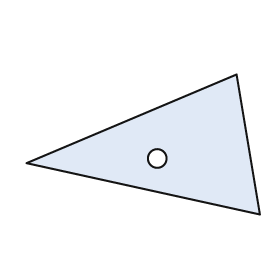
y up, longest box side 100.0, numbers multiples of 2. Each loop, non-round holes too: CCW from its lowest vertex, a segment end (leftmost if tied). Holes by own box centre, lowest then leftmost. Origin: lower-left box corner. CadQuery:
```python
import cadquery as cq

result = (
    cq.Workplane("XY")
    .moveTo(100.0, 0.0)
    .lineTo(90.0, 60.0)
    .lineTo(0.0, 22.0)
    .close()
    .moveTo(56.0, 24.0)
    .circle(4.0)
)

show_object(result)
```